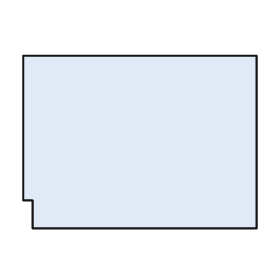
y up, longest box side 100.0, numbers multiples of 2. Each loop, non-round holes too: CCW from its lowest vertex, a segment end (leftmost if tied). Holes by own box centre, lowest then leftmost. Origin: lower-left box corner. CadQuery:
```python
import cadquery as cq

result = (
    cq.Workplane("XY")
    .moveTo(4.0, 0.0)
    .lineTo(100.0, 0.0)
    .lineTo(100.0, 74.0)
    .lineTo(0.0, 74.0)
    .lineTo(0.0, 12.0)
    .lineTo(4.0, 12.0)
    .close()
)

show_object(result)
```